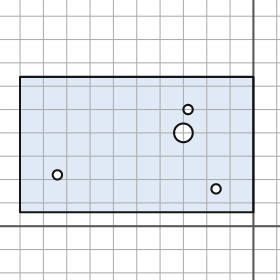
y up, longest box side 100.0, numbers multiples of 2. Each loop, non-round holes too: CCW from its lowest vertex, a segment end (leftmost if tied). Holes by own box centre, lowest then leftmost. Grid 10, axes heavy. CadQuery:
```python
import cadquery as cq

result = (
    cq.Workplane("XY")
    .moveTo(-100.0, 6.0)
    .lineTo(0.0, 6.0)
    .lineTo(0.0, 64.0)
    .lineTo(-100.0, 64.0)
    .close()
    .moveTo(-16.0, 16.0)
    .circle(2.0)
    .moveTo(-84.0, 22.0)
    .circle(2.0)
    .moveTo(-30.0, 40.0)
    .circle(4.0)
    .moveTo(-28.0, 50.0)
    .circle(2.0)
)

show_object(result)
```